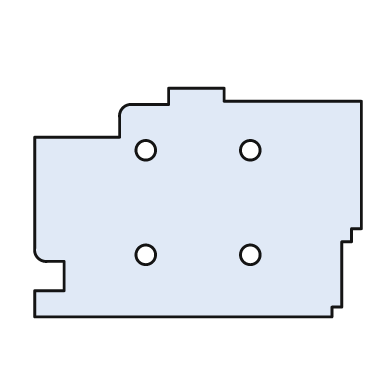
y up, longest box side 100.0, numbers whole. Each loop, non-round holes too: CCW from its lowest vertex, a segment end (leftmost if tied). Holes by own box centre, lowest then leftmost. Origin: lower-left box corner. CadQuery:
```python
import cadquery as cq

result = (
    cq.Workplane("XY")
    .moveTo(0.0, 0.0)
    .lineTo(91.0, 0.0)
    .lineTo(91.0, 3.0)
    .lineTo(94.0, 3.0)
    .lineTo(94.0, 23.0)
    .lineTo(97.0, 23.0)
    .lineTo(97.0, 27.0)
    .lineTo(100.0, 27.0)
    .lineTo(100.0, 66.0)
    .lineTo(58.0, 66.0)
    .lineTo(58.0, 70.0)
    .lineTo(41.0, 70.0)
    .lineTo(41.0, 65.0)
    .lineTo(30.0, 65.0)
    .threePointArc((27.0, 64.0), (26.0, 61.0))
    .lineTo(26.0, 55.0)
    .lineTo(0.0, 55.0)
    .lineTo(0.0, 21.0)
    .threePointArc((1.0, 18.0), (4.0, 17.0))
    .lineTo(9.0, 17.0)
    .lineTo(9.0, 8.0)
    .lineTo(0.0, 8.0)
    .close()
    .moveTo(34.0, 19.0)
    .circle(3.0)
    .moveTo(66.0, 19.0)
    .circle(3.0)
    .moveTo(34.0, 51.0)
    .circle(3.0)
    .moveTo(66.0, 51.0)
    .circle(3.0)
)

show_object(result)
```